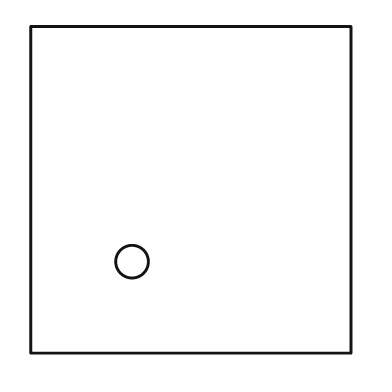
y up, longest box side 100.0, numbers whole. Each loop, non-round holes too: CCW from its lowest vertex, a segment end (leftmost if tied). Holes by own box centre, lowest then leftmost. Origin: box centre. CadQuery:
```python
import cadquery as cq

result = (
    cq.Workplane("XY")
    .moveTo(-49.0, -50.0)
    .lineTo(49.0, -50.0)
    .lineTo(49.0, 50.0)
    .lineTo(-49.0, 50.0)
    .close()
    .moveTo(-18.0, -22.0)
    .circle(5.0)
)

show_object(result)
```